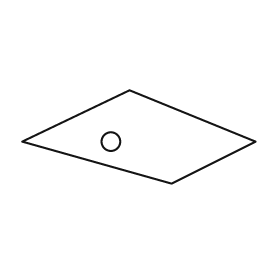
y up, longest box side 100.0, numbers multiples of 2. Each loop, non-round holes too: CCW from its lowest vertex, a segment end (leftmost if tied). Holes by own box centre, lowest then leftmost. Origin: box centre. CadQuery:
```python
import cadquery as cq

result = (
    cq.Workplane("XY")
    .moveTo(14.0, -20.0)
    .lineTo(50.0, -2.0)
    .lineTo(-4.0, 20.0)
    .lineTo(-50.0, -2.0)
    .close()
    .moveTo(-12.0, -2.0)
    .circle(4.0)
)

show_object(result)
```